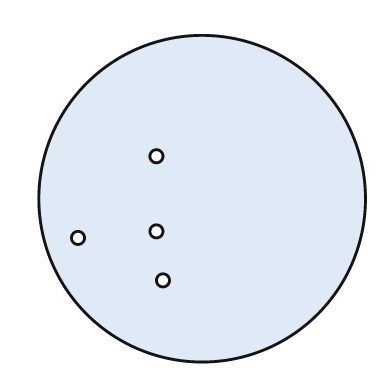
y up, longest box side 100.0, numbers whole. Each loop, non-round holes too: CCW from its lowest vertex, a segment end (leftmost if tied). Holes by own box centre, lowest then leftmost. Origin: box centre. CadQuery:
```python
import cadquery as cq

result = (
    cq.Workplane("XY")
    .moveTo(0.0, 0.0)
    .circle(50.0)
    .moveTo(-12.0, -25.0)
    .circle(2.0)
    .moveTo(-38.0, -12.0)
    .circle(2.0)
    .moveTo(-14.0, -10.0)
    .circle(2.0)
    .moveTo(-14.0, 13.0)
    .circle(2.0)
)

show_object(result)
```